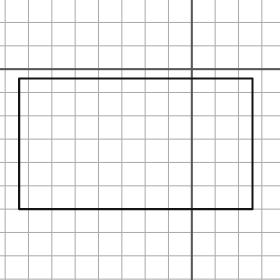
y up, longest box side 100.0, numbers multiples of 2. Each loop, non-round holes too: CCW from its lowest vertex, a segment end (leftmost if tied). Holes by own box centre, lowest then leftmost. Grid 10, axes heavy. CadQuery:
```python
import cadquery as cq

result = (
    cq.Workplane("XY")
    .moveTo(-74.0, -60.0)
    .lineTo(26.0, -60.0)
    .lineTo(26.0, -4.0)
    .lineTo(-74.0, -4.0)
    .close()
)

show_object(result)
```